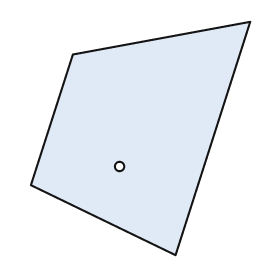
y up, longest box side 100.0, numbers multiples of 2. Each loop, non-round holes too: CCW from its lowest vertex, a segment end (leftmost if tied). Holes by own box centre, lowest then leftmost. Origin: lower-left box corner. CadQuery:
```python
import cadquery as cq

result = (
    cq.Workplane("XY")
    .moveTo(62.0, 0.0)
    .lineTo(94.0, 100.0)
    .lineTo(18.0, 86.0)
    .lineTo(0.0, 30.0)
    .close()
    .moveTo(38.0, 38.0)
    .circle(2.0)
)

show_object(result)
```